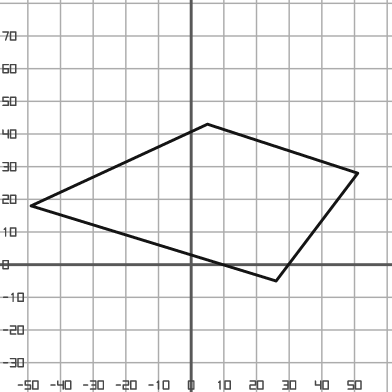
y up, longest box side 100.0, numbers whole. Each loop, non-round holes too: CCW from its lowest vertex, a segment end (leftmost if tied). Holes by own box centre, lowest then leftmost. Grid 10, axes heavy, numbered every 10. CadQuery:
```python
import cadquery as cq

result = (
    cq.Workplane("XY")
    .moveTo(26.0, -5.0)
    .lineTo(51.0, 28.0)
    .lineTo(5.0, 43.0)
    .lineTo(-49.0, 18.0)
    .close()
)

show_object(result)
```